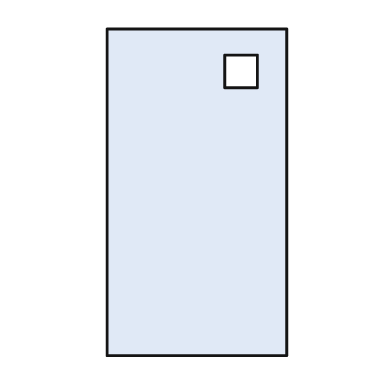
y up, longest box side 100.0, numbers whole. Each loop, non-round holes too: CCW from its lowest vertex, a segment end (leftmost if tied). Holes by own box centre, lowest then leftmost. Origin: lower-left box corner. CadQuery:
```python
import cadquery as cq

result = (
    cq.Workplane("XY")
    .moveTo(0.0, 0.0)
    .lineTo(55.0, 0.0)
    .lineTo(55.0, 100.0)
    .lineTo(0.0, 100.0)
    .close()
    .moveTo(36.0, 82.0)
    .lineTo(46.0, 82.0)
    .lineTo(46.0, 92.0)
    .lineTo(36.0, 92.0)
    .close()
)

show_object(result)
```